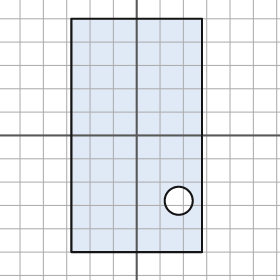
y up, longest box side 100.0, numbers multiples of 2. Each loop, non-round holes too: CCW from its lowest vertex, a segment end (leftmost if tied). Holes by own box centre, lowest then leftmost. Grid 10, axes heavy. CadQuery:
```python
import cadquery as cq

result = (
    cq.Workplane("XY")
    .moveTo(-28.0, -50.0)
    .lineTo(28.0, -50.0)
    .lineTo(28.0, 50.0)
    .lineTo(-28.0, 50.0)
    .close()
    .moveTo(18.0, -28.0)
    .circle(6.0)
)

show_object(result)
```